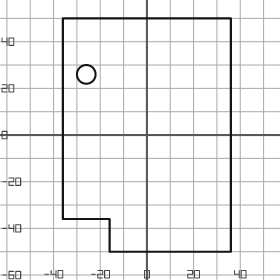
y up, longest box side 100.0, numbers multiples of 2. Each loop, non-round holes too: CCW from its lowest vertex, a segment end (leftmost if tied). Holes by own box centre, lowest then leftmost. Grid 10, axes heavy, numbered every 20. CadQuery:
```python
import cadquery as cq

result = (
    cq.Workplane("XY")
    .moveTo(-16.0, -50.0)
    .lineTo(36.0, -50.0)
    .lineTo(36.0, 50.0)
    .lineTo(-36.0, 50.0)
    .lineTo(-36.0, -36.0)
    .lineTo(-16.0, -36.0)
    .close()
    .moveTo(-26.0, 26.0)
    .circle(4.0)
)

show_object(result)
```